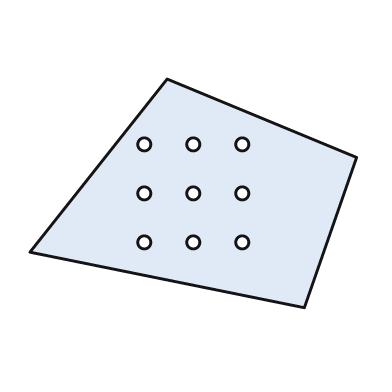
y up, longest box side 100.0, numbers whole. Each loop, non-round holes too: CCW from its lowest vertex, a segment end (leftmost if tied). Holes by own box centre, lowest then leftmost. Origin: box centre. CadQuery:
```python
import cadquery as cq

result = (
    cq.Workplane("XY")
    .moveTo(34.0, -35.0)
    .lineTo(50.0, 11.0)
    .lineTo(-8.0, 35.0)
    .lineTo(-50.0, -18.0)
    .close()
    .moveTo(-15.0, -15.0)
    .circle(2.0)
    .moveTo(0.0, -15.0)
    .circle(2.0)
    .moveTo(15.0, -15.0)
    .circle(2.0)
    .moveTo(-15.0, 0.0)
    .circle(2.0)
    .moveTo(0.0, 0.0)
    .circle(2.0)
    .moveTo(15.0, 0.0)
    .circle(2.0)
    .moveTo(-15.0, 15.0)
    .circle(2.0)
    .moveTo(0.0, 15.0)
    .circle(2.0)
    .moveTo(15.0, 15.0)
    .circle(2.0)
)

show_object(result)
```